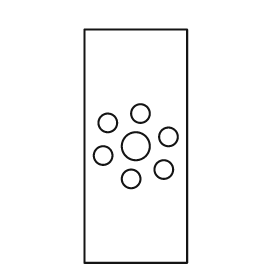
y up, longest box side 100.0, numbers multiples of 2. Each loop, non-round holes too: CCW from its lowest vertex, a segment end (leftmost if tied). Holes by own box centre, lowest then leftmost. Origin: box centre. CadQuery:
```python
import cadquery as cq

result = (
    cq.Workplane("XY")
    .moveTo(-22.0, -50.0)
    .lineTo(22.0, -50.0)
    .lineTo(22.0, 50.0)
    .lineTo(-22.0, 50.0)
    .close()
    .moveTo(-2.0, -14.0)
    .circle(4.0)
    .moveTo(12.0, -10.0)
    .circle(4.0)
    .moveTo(-14.0, -4.0)
    .circle(4.0)
    .moveTo(0.0, 0.0)
    .circle(6.0)
    .moveTo(14.0, 4.0)
    .circle(4.0)
    .moveTo(-12.0, 10.0)
    .circle(4.0)
    .moveTo(2.0, 14.0)
    .circle(4.0)
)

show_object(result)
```